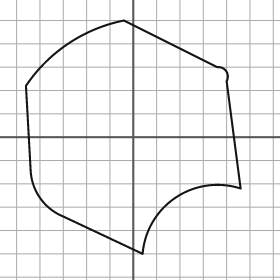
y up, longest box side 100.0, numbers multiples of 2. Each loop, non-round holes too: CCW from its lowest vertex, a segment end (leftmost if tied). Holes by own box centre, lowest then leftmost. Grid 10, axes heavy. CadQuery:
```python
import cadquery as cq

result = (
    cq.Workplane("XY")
    .moveTo(4.0, -50.0)
    .threePointArc((18.0, -26.0), (46.0, -22.0))
    .lineTo(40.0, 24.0)
    .threePointArc((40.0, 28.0), (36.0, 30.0))
    .lineTo(-4.0, 50.0)
    .threePointArc((-28.0, 40.0), (-46.0, 22.0))
    .lineTo(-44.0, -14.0)
    .threePointArc((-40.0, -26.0), (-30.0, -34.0))
    .close()
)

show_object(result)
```